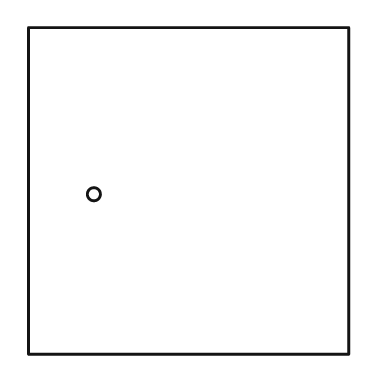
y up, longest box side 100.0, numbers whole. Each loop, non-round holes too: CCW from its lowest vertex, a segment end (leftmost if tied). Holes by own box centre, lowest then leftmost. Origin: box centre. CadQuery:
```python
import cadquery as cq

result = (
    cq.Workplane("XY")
    .moveTo(-49.0, -50.0)
    .lineTo(49.0, -50.0)
    .lineTo(49.0, 50.0)
    .lineTo(-49.0, 50.0)
    .close()
    .moveTo(-29.0, -1.0)
    .circle(2.0)
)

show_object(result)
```